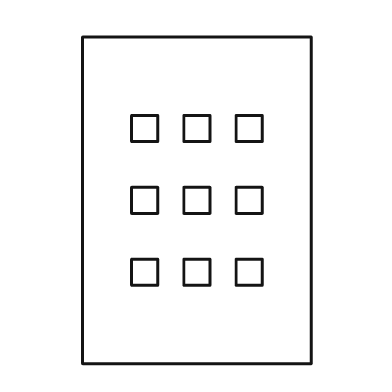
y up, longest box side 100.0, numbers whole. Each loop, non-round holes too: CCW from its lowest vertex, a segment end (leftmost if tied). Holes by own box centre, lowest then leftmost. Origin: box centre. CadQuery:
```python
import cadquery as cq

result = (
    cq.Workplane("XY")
    .moveTo(-35.0, -50.0)
    .lineTo(35.0, -50.0)
    .lineTo(35.0, 50.0)
    .lineTo(-35.0, 50.0)
    .close()
    .moveTo(-20.0, -26.0)
    .lineTo(-12.0, -26.0)
    .lineTo(-12.0, -18.0)
    .lineTo(-20.0, -18.0)
    .close()
    .moveTo(-4.0, -26.0)
    .lineTo(4.0, -26.0)
    .lineTo(4.0, -18.0)
    .lineTo(-4.0, -18.0)
    .close()
    .moveTo(12.0, -26.0)
    .lineTo(20.0, -26.0)
    .lineTo(20.0, -18.0)
    .lineTo(12.0, -18.0)
    .close()
    .moveTo(-20.0, -4.0)
    .lineTo(-12.0, -4.0)
    .lineTo(-12.0, 4.0)
    .lineTo(-20.0, 4.0)
    .close()
    .moveTo(-4.0, -4.0)
    .lineTo(4.0, -4.0)
    .lineTo(4.0, 4.0)
    .lineTo(-4.0, 4.0)
    .close()
    .moveTo(12.0, -4.0)
    .lineTo(20.0, -4.0)
    .lineTo(20.0, 4.0)
    .lineTo(12.0, 4.0)
    .close()
    .moveTo(-20.0, 18.0)
    .lineTo(-12.0, 18.0)
    .lineTo(-12.0, 26.0)
    .lineTo(-20.0, 26.0)
    .close()
    .moveTo(-4.0, 18.0)
    .lineTo(4.0, 18.0)
    .lineTo(4.0, 26.0)
    .lineTo(-4.0, 26.0)
    .close()
    .moveTo(12.0, 18.0)
    .lineTo(20.0, 18.0)
    .lineTo(20.0, 26.0)
    .lineTo(12.0, 26.0)
    .close()
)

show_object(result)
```